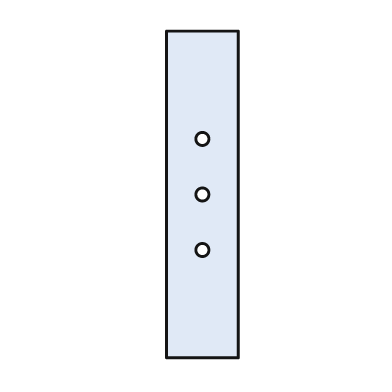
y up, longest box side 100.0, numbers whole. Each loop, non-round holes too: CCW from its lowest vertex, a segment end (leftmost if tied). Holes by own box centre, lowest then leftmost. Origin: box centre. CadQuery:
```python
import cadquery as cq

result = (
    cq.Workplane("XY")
    .moveTo(-11.0, -50.0)
    .lineTo(11.0, -50.0)
    .lineTo(11.0, 50.0)
    .lineTo(-11.0, 50.0)
    .close()
    .moveTo(0.0, -17.0)
    .circle(2.0)
    .moveTo(0.0, 0.0)
    .circle(2.0)
    .moveTo(0.0, 17.0)
    .circle(2.0)
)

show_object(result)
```